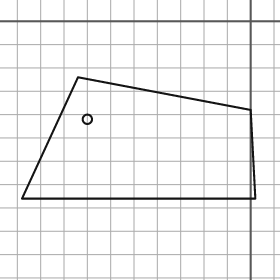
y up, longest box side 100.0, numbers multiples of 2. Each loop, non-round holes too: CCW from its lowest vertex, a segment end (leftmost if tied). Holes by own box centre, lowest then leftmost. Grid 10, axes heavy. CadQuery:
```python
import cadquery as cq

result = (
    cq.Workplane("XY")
    .moveTo(-98.0, -76.0)
    .lineTo(2.0, -76.0)
    .lineTo(0.0, -38.0)
    .lineTo(-74.0, -24.0)
    .close()
    .moveTo(-70.0, -42.0)
    .circle(2.0)
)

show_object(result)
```